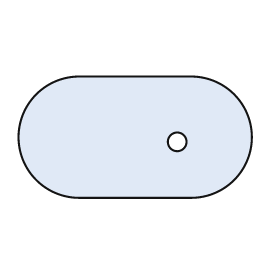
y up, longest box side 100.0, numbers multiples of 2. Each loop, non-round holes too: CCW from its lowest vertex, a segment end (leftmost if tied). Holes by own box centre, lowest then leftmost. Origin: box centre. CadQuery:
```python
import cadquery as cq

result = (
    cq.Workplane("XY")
    .moveTo(-24.0, -26.0)
    .lineTo(24.0, -26.0)
    .threePointArc((50.0, 0.0), (24.0, 26.0))
    .lineTo(-24.0, 26.0)
    .threePointArc((-50.0, 0.0), (-24.0, -26.0))
    .close()
    .moveTo(18.0, -2.0)
    .circle(4.0)
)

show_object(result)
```